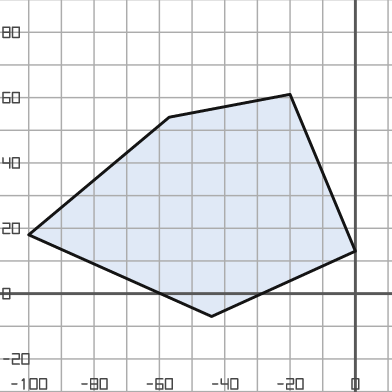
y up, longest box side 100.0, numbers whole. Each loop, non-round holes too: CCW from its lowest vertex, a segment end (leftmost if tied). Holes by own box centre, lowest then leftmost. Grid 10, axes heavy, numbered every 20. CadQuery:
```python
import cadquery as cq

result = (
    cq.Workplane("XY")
    .moveTo(-44.0, -7.0)
    .lineTo(0.0, 13.0)
    .lineTo(-20.0, 61.0)
    .lineTo(-57.0, 54.0)
    .lineTo(-100.0, 18.0)
    .close()
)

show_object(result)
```